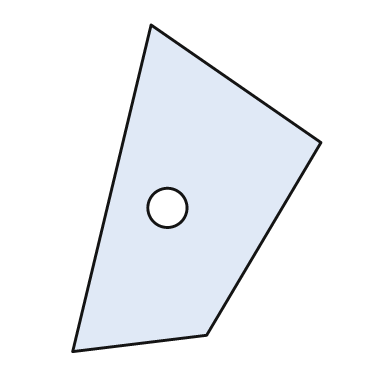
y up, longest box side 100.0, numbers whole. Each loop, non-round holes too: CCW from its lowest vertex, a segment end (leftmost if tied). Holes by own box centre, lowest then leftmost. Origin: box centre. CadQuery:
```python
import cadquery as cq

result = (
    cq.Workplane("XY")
    .moveTo(-38.0, -50.0)
    .lineTo(3.0, -45.0)
    .lineTo(38.0, 14.0)
    .lineTo(-14.0, 50.0)
    .close()
    .moveTo(-9.0, -6.0)
    .circle(6.0)
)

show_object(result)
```